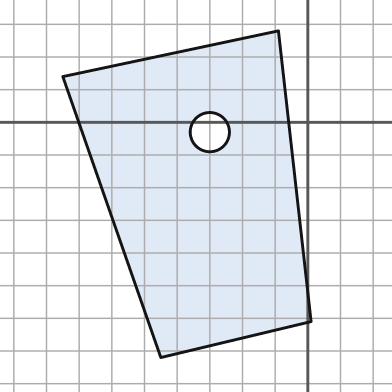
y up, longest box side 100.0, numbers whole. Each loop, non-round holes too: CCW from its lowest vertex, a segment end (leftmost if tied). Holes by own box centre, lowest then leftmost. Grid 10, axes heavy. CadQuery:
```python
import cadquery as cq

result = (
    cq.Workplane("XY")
    .moveTo(-45.0, -72.0)
    .lineTo(1.0, -61.0)
    .lineTo(-9.0, 28.0)
    .lineTo(-75.0, 14.0)
    .close()
    .moveTo(-30.0, -3.0)
    .circle(6.0)
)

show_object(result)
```